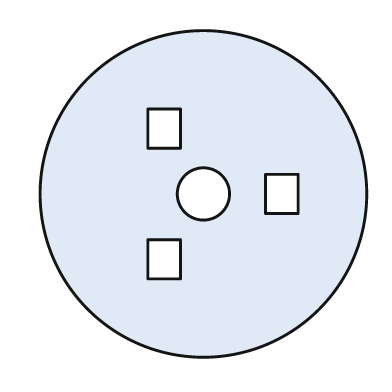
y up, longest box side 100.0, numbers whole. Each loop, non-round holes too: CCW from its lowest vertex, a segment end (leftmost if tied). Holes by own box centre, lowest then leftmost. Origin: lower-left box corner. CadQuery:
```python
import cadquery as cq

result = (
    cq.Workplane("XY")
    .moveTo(50.0, 50.0)
    .circle(50.0)
    .moveTo(33.0, 24.0)
    .lineTo(43.0, 24.0)
    .lineTo(43.0, 36.0)
    .lineTo(33.0, 36.0)
    .close()
    .moveTo(50.0, 50.0)
    .circle(8.0)
    .moveTo(69.0, 44.0)
    .lineTo(79.0, 44.0)
    .lineTo(79.0, 56.0)
    .lineTo(69.0, 56.0)
    .close()
    .moveTo(33.0, 64.0)
    .lineTo(43.0, 64.0)
    .lineTo(43.0, 76.0)
    .lineTo(33.0, 76.0)
    .close()
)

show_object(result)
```